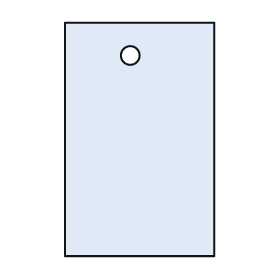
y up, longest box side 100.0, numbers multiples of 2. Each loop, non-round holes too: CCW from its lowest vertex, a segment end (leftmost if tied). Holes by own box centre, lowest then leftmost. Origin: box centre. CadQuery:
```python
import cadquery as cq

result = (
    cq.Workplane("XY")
    .moveTo(-32.0, -50.0)
    .lineTo(32.0, -50.0)
    .lineTo(32.0, 50.0)
    .lineTo(-32.0, 50.0)
    .close()
    .moveTo(-4.0, 36.0)
    .circle(4.0)
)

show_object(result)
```